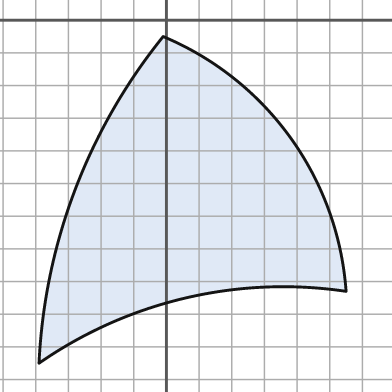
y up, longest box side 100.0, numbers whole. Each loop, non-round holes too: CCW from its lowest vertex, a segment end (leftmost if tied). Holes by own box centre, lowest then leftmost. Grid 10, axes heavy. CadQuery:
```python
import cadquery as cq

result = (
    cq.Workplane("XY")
    .moveTo(-39.0, -105.0)
    .threePointArc((6.0, -85.0), (55.0, -83.0))
    .threePointArc((38.0, -36.0), (-1.0, -5.0))
    .threePointArc((-28.0, -52.0), (-39.0, -105.0))
    .close()
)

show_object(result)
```